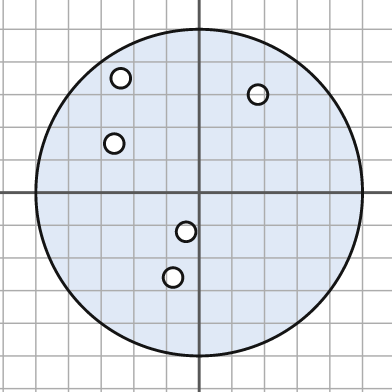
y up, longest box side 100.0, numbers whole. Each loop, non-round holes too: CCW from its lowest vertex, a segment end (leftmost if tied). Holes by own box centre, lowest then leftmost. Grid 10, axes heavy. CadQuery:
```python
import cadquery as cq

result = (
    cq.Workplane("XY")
    .moveTo(0.0, 0.0)
    .circle(50.0)
    .moveTo(-8.0, -26.0)
    .circle(3.0)
    .moveTo(-4.0, -12.0)
    .circle(3.0)
    .moveTo(-26.0, 15.0)
    .circle(3.0)
    .moveTo(18.0, 30.0)
    .circle(3.0)
    .moveTo(-24.0, 35.0)
    .circle(3.0)
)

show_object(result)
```